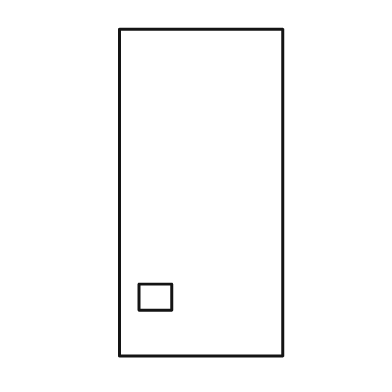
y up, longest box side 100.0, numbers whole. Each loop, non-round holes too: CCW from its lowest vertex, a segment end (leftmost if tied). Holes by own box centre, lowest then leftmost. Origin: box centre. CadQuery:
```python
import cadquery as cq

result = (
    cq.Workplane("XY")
    .moveTo(-25.0, -50.0)
    .lineTo(25.0, -50.0)
    .lineTo(25.0, 50.0)
    .lineTo(-25.0, 50.0)
    .close()
    .moveTo(-19.0, -36.0)
    .lineTo(-9.0, -36.0)
    .lineTo(-9.0, -28.0)
    .lineTo(-19.0, -28.0)
    .close()
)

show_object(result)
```